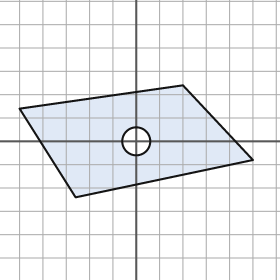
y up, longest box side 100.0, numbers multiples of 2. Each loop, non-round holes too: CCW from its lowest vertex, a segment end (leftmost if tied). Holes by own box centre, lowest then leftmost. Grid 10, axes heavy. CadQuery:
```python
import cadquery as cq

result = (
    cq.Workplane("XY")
    .moveTo(-26.0, -24.0)
    .lineTo(50.0, -8.0)
    .lineTo(20.0, 24.0)
    .lineTo(-50.0, 14.0)
    .close()
    .moveTo(0.0, 0.0)
    .circle(6.0)
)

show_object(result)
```